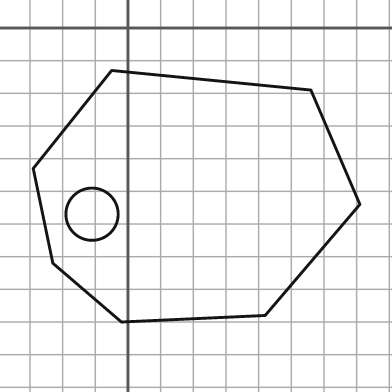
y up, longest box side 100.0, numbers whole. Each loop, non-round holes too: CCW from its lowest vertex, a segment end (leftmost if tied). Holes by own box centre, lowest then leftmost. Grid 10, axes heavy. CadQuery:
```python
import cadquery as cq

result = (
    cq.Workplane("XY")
    .moveTo(-2.0, -90.0)
    .lineTo(42.0, -88.0)
    .lineTo(71.0, -54.0)
    .lineTo(56.0, -19.0)
    .lineTo(-5.0, -13.0)
    .lineTo(-29.0, -43.0)
    .lineTo(-23.0, -72.0)
    .close()
    .moveTo(-11.0, -57.0)
    .circle(8.0)
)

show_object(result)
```